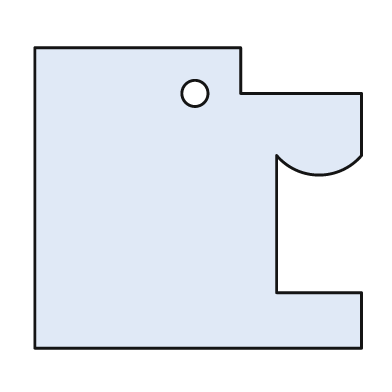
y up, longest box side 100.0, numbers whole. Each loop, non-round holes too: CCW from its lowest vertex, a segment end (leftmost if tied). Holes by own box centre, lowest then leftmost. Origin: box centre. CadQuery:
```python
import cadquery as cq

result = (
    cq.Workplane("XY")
    .moveTo(-50.0, -46.0)
    .lineTo(50.0, -46.0)
    .lineTo(50.0, -29.0)
    .lineTo(24.0, -29.0)
    .lineTo(24.0, 13.0)
    .threePointArc((37.0, 7.0), (50.0, 13.0))
    .lineTo(50.0, 32.0)
    .lineTo(13.0, 32.0)
    .lineTo(13.0, 46.0)
    .lineTo(-50.0, 46.0)
    .close()
    .moveTo(-1.0, 32.0)
    .circle(4.0)
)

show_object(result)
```